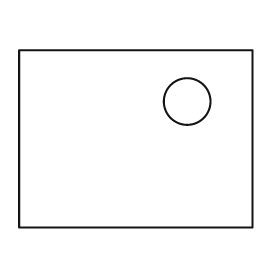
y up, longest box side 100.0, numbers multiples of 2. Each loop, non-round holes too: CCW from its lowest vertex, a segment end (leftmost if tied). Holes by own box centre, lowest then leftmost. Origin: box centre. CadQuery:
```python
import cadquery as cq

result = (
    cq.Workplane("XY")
    .moveTo(-50.0, -38.0)
    .lineTo(50.0, -38.0)
    .lineTo(50.0, 38.0)
    .lineTo(-50.0, 38.0)
    .close()
    .moveTo(22.0, 16.0)
    .circle(10.0)
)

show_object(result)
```